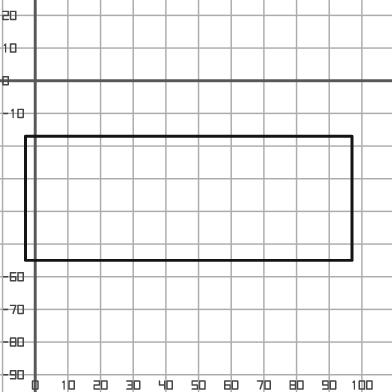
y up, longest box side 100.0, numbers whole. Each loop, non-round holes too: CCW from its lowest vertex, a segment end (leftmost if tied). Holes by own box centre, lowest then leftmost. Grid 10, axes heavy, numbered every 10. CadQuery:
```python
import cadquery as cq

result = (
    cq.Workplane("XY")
    .moveTo(-3.0, -55.0)
    .lineTo(97.0, -55.0)
    .lineTo(97.0, -17.0)
    .lineTo(-3.0, -17.0)
    .close()
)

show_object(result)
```